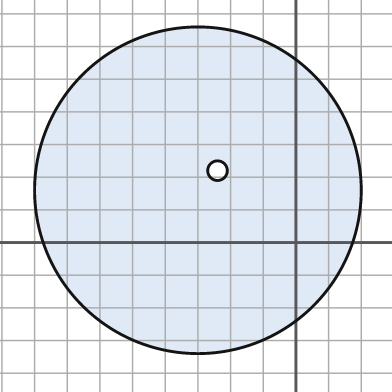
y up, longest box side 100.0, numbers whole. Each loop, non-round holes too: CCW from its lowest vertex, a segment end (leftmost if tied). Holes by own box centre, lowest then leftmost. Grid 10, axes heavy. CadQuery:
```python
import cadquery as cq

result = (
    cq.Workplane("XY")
    .moveTo(-30.0, 16.0)
    .circle(50.0)
    .moveTo(-24.0, 22.0)
    .circle(3.0)
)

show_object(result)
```